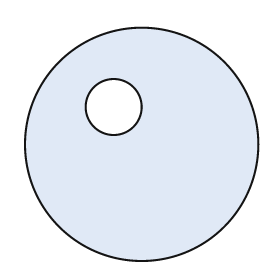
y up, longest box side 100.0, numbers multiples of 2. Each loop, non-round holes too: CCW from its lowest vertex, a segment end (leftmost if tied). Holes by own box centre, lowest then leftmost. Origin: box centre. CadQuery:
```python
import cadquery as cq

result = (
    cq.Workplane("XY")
    .moveTo(0.0, 0.0)
    .circle(50.0)
    .moveTo(-12.0, 16.0)
    .circle(12.0)
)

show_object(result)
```